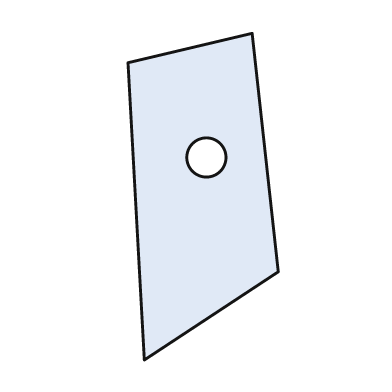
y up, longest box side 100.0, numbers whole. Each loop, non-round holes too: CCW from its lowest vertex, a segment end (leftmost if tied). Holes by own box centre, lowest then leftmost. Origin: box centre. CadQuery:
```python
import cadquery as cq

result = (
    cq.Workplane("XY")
    .moveTo(-18.0, -50.0)
    .lineTo(23.0, -23.0)
    .lineTo(15.0, 50.0)
    .lineTo(-23.0, 41.0)
    .close()
    .moveTo(1.0, 12.0)
    .circle(6.0)
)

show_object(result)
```